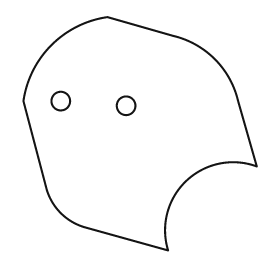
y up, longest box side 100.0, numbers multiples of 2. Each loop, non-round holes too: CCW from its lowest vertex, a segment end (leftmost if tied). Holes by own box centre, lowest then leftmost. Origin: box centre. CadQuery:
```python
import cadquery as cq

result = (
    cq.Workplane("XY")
    .moveTo(12.0, -50.0)
    .threePointArc((20.0, -20.0), (50.0, -14.0))
    .lineTo(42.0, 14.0)
    .threePointArc((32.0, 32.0), (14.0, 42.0))
    .lineTo(-14.0, 50.0)
    .threePointArc((-38.0, 38.0), (-50.0, 14.0))
    .lineTo(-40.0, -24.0)
    .threePointArc((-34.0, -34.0), (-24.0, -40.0))
    .close()
    .moveTo(-6.0, 12.0)
    .circle(4.0)
    .moveTo(-34.0, 14.0)
    .circle(4.0)
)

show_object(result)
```